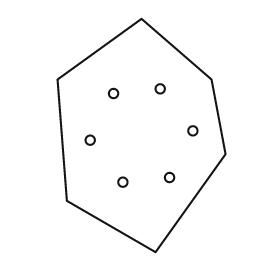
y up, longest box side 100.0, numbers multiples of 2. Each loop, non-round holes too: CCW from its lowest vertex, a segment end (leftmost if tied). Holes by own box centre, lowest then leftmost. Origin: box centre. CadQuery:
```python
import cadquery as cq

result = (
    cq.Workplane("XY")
    .moveTo(6.0, -50.0)
    .lineTo(36.0, -8.0)
    .lineTo(30.0, 24.0)
    .lineTo(0.0, 50.0)
    .lineTo(-36.0, 24.0)
    .lineTo(-32.0, -28.0)
    .close()
    .moveTo(-8.0, -20.0)
    .circle(2.0)
    .moveTo(12.0, -18.0)
    .circle(2.0)
    .moveTo(-22.0, -2.0)
    .circle(2.0)
    .moveTo(22.0, 2.0)
    .circle(2.0)
    .moveTo(-12.0, 18.0)
    .circle(2.0)
    .moveTo(8.0, 20.0)
    .circle(2.0)
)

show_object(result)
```